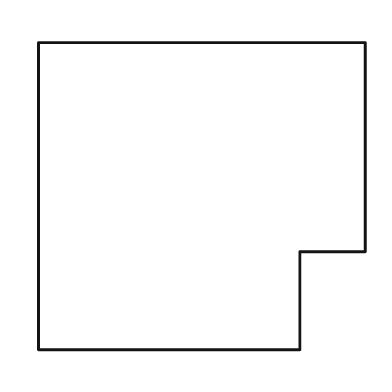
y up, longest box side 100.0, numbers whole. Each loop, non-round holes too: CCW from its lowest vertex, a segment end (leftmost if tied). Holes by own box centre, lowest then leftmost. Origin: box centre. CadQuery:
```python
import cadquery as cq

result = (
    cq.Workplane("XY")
    .moveTo(-50.0, -47.0)
    .lineTo(30.0, -47.0)
    .lineTo(30.0, -17.0)
    .lineTo(50.0, -17.0)
    .lineTo(50.0, 47.0)
    .lineTo(-50.0, 47.0)
    .close()
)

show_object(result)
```